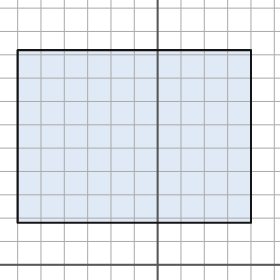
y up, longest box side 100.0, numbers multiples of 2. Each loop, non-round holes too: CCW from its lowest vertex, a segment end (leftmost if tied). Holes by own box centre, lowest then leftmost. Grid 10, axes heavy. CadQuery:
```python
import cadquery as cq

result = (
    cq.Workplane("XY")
    .moveTo(-60.0, 18.0)
    .lineTo(40.0, 18.0)
    .lineTo(40.0, 92.0)
    .lineTo(-60.0, 92.0)
    .close()
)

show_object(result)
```